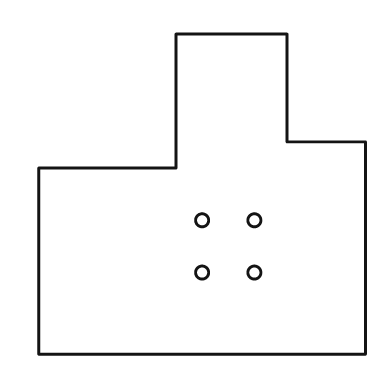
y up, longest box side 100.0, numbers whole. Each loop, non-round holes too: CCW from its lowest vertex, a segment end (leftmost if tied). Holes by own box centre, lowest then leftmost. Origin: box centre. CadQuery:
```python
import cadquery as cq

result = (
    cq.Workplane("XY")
    .moveTo(-50.0, -49.0)
    .lineTo(50.0, -49.0)
    .lineTo(50.0, 16.0)
    .lineTo(26.0, 16.0)
    .lineTo(26.0, 49.0)
    .lineTo(-8.0, 49.0)
    .lineTo(-8.0, 8.0)
    .lineTo(-50.0, 8.0)
    .close()
    .moveTo(0.0, -24.0)
    .circle(2.0)
    .moveTo(16.0, -24.0)
    .circle(2.0)
    .moveTo(0.0, -8.0)
    .circle(2.0)
    .moveTo(16.0, -8.0)
    .circle(2.0)
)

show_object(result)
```